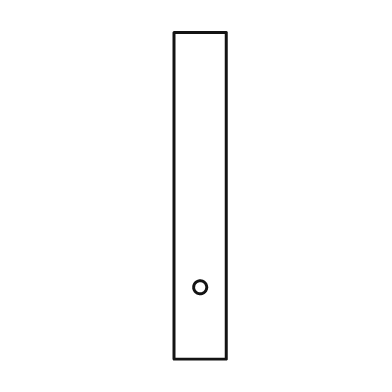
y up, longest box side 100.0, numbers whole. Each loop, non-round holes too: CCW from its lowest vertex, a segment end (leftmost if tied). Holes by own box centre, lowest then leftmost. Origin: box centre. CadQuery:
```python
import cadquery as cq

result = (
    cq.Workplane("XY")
    .moveTo(-8.0, -50.0)
    .lineTo(8.0, -50.0)
    .lineTo(8.0, 50.0)
    .lineTo(-8.0, 50.0)
    .close()
    .moveTo(0.0, -28.0)
    .circle(2.0)
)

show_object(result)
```